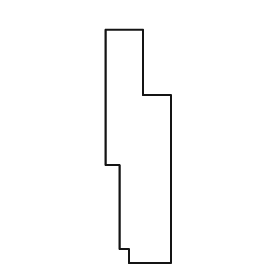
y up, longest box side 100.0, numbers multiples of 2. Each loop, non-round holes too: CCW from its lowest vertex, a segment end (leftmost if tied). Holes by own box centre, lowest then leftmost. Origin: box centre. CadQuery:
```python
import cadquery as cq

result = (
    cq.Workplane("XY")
    .moveTo(-4.0, -50.0)
    .lineTo(14.0, -50.0)
    .lineTo(14.0, 22.0)
    .lineTo(2.0, 22.0)
    .lineTo(2.0, 50.0)
    .lineTo(-14.0, 50.0)
    .lineTo(-14.0, -8.0)
    .lineTo(-8.0, -8.0)
    .lineTo(-8.0, -44.0)
    .lineTo(-4.0, -44.0)
    .close()
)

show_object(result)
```